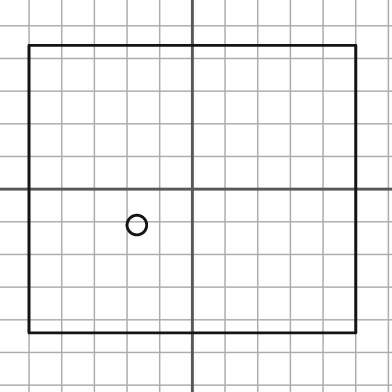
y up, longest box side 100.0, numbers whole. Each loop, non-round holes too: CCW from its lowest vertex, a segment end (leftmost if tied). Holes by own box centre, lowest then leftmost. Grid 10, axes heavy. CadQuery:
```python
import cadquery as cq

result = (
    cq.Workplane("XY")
    .moveTo(-50.0, -44.0)
    .lineTo(50.0, -44.0)
    .lineTo(50.0, 44.0)
    .lineTo(-50.0, 44.0)
    .close()
    .moveTo(-17.0, -11.0)
    .circle(3.0)
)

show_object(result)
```